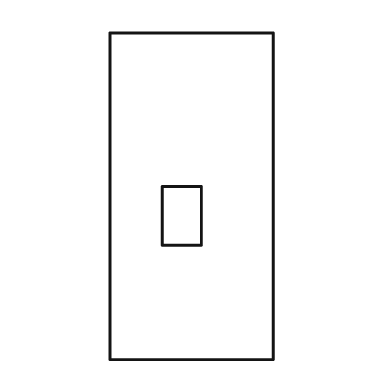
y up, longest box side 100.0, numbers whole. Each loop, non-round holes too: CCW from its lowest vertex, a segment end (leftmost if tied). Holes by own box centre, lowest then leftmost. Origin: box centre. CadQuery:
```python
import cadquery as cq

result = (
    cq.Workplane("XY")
    .moveTo(-25.0, -50.0)
    .lineTo(25.0, -50.0)
    .lineTo(25.0, 50.0)
    .lineTo(-25.0, 50.0)
    .close()
    .moveTo(-9.0, -15.0)
    .lineTo(3.0, -15.0)
    .lineTo(3.0, 3.0)
    .lineTo(-9.0, 3.0)
    .close()
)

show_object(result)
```